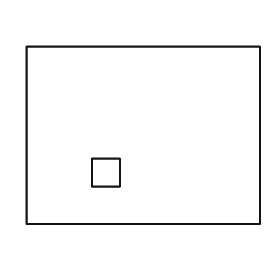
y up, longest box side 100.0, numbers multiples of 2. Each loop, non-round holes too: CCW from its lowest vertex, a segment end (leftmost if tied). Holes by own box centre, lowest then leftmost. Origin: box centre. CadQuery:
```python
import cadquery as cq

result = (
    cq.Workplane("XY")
    .moveTo(-50.0, -38.0)
    .lineTo(50.0, -38.0)
    .lineTo(50.0, 38.0)
    .lineTo(-50.0, 38.0)
    .close()
    .moveTo(-22.0, -22.0)
    .lineTo(-10.0, -22.0)
    .lineTo(-10.0, -10.0)
    .lineTo(-22.0, -10.0)
    .close()
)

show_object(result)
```